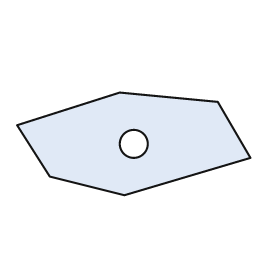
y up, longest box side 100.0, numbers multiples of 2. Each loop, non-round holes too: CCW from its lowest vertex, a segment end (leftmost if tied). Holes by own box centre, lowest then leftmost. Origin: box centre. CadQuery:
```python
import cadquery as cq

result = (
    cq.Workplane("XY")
    .moveTo(-4.0, -22.0)
    .lineTo(50.0, -6.0)
    .lineTo(36.0, 18.0)
    .lineTo(-6.0, 22.0)
    .lineTo(-50.0, 8.0)
    .lineTo(-36.0, -14.0)
    .close()
    .moveTo(0.0, 0.0)
    .circle(6.0)
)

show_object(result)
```